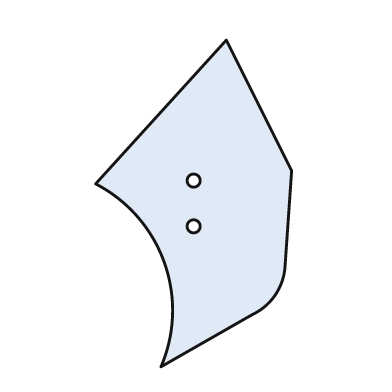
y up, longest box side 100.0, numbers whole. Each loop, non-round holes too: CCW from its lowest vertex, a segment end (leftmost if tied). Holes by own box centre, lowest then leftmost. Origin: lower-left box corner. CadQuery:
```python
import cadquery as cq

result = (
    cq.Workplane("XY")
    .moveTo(20.0, 0.0)
    .lineTo(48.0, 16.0)
    .threePointArc((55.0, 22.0), (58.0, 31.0))
    .lineTo(60.0, 60.0)
    .lineTo(40.0, 100.0)
    .lineTo(0.0, 56.0)
    .threePointArc((21.0, 32.0), (20.0, 0.0))
    .close()
    .moveTo(30.0, 43.0)
    .circle(2.0)
    .moveTo(30.0, 57.0)
    .circle(2.0)
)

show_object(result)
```